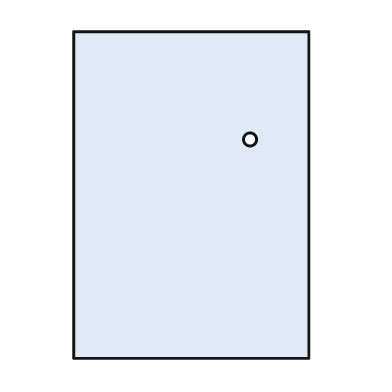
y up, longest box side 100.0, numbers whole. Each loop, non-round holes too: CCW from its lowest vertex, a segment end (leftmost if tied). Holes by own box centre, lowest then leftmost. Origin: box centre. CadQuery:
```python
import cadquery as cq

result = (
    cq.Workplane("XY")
    .moveTo(-36.0, -50.0)
    .lineTo(36.0, -50.0)
    .lineTo(36.0, 50.0)
    .lineTo(-36.0, 50.0)
    .close()
    .moveTo(18.0, 17.0)
    .circle(2.0)
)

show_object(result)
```